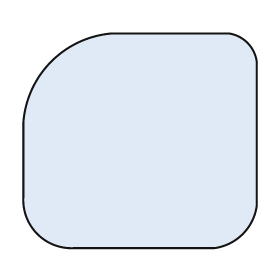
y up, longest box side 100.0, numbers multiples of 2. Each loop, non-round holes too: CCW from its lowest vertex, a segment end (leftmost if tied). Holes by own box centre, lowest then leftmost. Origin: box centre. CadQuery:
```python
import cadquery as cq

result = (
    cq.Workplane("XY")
    .moveTo(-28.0, -46.0)
    .lineTo(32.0, -46.0)
    .threePointArc((44.0, -40.0), (50.0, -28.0))
    .lineTo(50.0, 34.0)
    .threePointArc((46.0, 42.0), (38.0, 46.0))
    .lineTo(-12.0, 46.0)
    .threePointArc((-38.0, 34.0), (-50.0, 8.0))
    .lineTo(-50.0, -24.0)
    .threePointArc((-44.0, -40.0), (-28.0, -46.0))
    .close()
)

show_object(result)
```